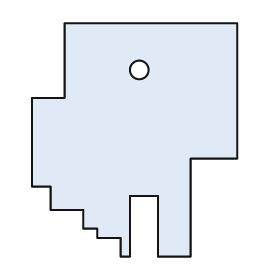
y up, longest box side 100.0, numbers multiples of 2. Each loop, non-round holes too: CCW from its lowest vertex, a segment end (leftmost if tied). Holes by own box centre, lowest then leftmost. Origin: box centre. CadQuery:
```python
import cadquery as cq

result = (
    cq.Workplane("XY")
    .moveTo(-6.0, -50.0)
    .lineTo(-2.0, -50.0)
    .lineTo(-2.0, -24.0)
    .lineTo(10.0, -24.0)
    .lineTo(10.0, -50.0)
    .lineTo(24.0, -50.0)
    .lineTo(24.0, -8.0)
    .lineTo(44.0, -8.0)
    .lineTo(44.0, 50.0)
    .lineTo(-30.0, 50.0)
    .lineTo(-30.0, 18.0)
    .lineTo(-44.0, 18.0)
    .lineTo(-44.0, -20.0)
    .lineTo(-36.0, -20.0)
    .lineTo(-36.0, -30.0)
    .lineTo(-22.0, -30.0)
    .lineTo(-22.0, -38.0)
    .lineTo(-16.0, -38.0)
    .lineTo(-16.0, -42.0)
    .lineTo(-6.0, -42.0)
    .close()
    .moveTo(2.0, 30.0)
    .circle(4.0)
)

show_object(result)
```